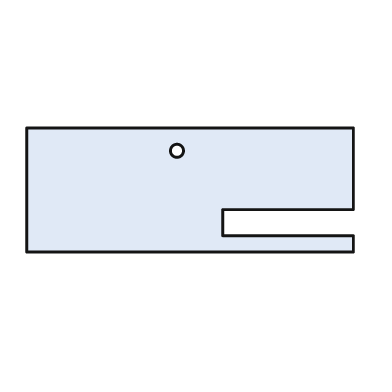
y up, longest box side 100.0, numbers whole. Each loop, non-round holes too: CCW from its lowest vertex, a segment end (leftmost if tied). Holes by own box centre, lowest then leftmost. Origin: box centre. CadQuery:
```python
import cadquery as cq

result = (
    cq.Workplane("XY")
    .moveTo(-50.0, -19.0)
    .lineTo(50.0, -19.0)
    .lineTo(50.0, -14.0)
    .lineTo(10.0, -14.0)
    .lineTo(10.0, -6.0)
    .lineTo(50.0, -6.0)
    .lineTo(50.0, 19.0)
    .lineTo(-50.0, 19.0)
    .close()
    .moveTo(-4.0, 12.0)
    .circle(2.0)
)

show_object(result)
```